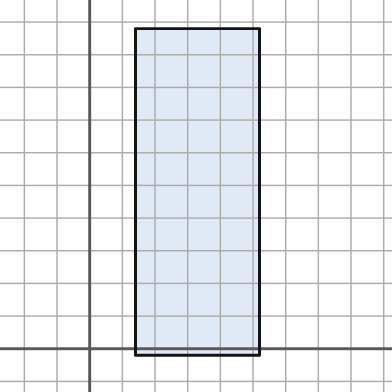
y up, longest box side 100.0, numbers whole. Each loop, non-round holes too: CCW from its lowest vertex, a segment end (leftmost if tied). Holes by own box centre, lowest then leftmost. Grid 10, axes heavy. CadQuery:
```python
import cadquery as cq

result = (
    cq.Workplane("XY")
    .moveTo(14.0, -2.0)
    .lineTo(52.0, -2.0)
    .lineTo(52.0, 98.0)
    .lineTo(14.0, 98.0)
    .close()
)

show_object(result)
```